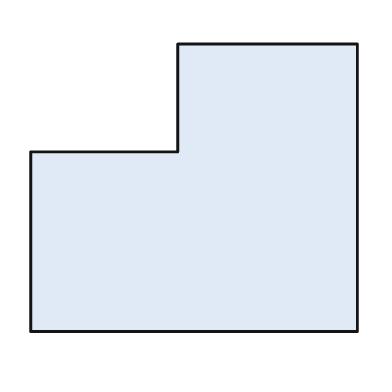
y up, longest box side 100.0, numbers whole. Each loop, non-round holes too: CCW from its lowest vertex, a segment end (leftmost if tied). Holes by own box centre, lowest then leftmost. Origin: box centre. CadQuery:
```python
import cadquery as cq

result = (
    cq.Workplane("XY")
    .moveTo(-50.0, -44.0)
    .lineTo(50.0, -44.0)
    .lineTo(50.0, 44.0)
    .lineTo(-5.0, 44.0)
    .lineTo(-5.0, 11.0)
    .lineTo(-50.0, 11.0)
    .close()
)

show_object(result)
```